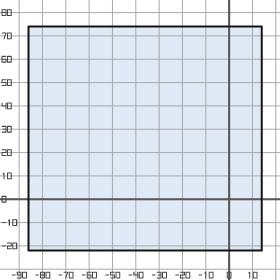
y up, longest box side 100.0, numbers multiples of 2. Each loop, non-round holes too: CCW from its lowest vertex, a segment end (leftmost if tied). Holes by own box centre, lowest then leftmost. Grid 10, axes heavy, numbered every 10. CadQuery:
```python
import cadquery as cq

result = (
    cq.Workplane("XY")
    .moveTo(-86.0, -22.0)
    .lineTo(14.0, -22.0)
    .lineTo(14.0, 74.0)
    .lineTo(-86.0, 74.0)
    .close()
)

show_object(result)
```